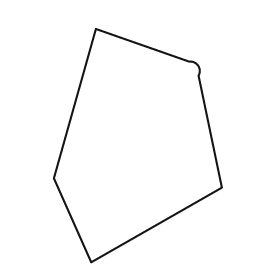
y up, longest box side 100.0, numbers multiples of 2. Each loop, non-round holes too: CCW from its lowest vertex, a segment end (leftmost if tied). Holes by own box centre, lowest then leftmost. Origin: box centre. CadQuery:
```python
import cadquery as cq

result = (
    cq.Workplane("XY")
    .moveTo(-20.0, -50.0)
    .lineTo(36.0, -18.0)
    .lineTo(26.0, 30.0)
    .threePointArc((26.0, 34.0), (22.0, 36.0))
    .lineTo(-18.0, 50.0)
    .lineTo(-36.0, -14.0)
    .close()
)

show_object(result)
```